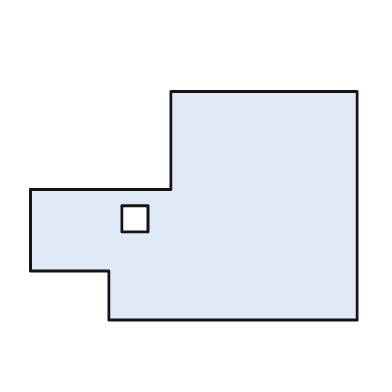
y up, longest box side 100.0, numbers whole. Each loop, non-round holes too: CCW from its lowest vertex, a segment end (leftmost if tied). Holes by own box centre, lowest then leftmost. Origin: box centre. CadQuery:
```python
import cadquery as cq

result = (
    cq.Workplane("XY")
    .moveTo(-26.0, -35.0)
    .lineTo(50.0, -35.0)
    .lineTo(50.0, 35.0)
    .lineTo(-7.0, 35.0)
    .lineTo(-7.0, 5.0)
    .lineTo(-50.0, 5.0)
    .lineTo(-50.0, -20.0)
    .lineTo(-26.0, -20.0)
    .close()
    .moveTo(-22.0, -8.0)
    .lineTo(-14.0, -8.0)
    .lineTo(-14.0, 0.0)
    .lineTo(-22.0, 0.0)
    .close()
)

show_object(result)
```